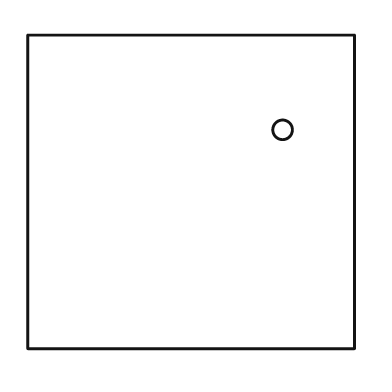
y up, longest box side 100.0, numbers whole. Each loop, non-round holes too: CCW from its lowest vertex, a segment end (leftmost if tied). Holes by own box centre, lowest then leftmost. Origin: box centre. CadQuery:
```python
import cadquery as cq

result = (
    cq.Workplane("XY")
    .moveTo(-50.0, -48.0)
    .lineTo(50.0, -48.0)
    .lineTo(50.0, 48.0)
    .lineTo(-50.0, 48.0)
    .close()
    .moveTo(28.0, 19.0)
    .circle(3.0)
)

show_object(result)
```